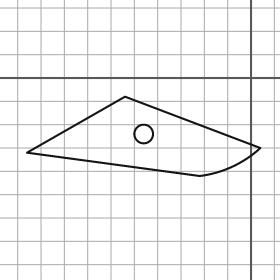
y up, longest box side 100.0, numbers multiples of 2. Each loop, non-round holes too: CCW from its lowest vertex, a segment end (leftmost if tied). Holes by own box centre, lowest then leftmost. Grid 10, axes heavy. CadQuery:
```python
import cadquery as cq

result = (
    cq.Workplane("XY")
    .moveTo(-22.0, -42.0)
    .threePointArc((-8.0, -38.0), (4.0, -30.0))
    .lineTo(-54.0, -8.0)
    .lineTo(-96.0, -32.0)
    .close()
    .moveTo(-46.0, -24.0)
    .circle(4.0)
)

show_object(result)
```